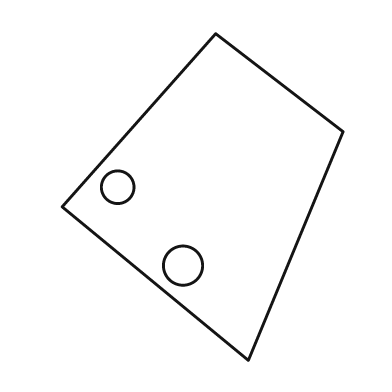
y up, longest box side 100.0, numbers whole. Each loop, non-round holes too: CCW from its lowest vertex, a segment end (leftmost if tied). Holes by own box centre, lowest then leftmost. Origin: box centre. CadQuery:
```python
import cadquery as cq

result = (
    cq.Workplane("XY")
    .moveTo(14.0, -50.0)
    .lineTo(43.0, 20.0)
    .lineTo(4.0, 50.0)
    .lineTo(-43.0, -3.0)
    .close()
    .moveTo(-6.0, -21.0)
    .circle(6.0)
    .moveTo(-26.0, 3.0)
    .circle(5.0)
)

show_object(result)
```